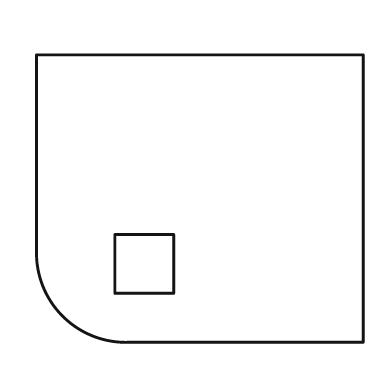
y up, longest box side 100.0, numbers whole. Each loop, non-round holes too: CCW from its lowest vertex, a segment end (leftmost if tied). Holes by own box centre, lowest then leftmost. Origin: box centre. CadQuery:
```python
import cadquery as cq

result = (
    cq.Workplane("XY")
    .moveTo(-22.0, -44.0)
    .lineTo(50.0, -44.0)
    .lineTo(50.0, 44.0)
    .lineTo(-50.0, 44.0)
    .lineTo(-50.0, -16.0)
    .threePointArc((-42.0, -36.0), (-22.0, -44.0))
    .close()
    .moveTo(-26.0, -29.0)
    .lineTo(-8.0, -29.0)
    .lineTo(-8.0, -11.0)
    .lineTo(-26.0, -11.0)
    .close()
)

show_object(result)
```